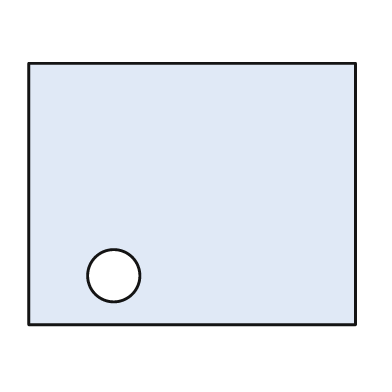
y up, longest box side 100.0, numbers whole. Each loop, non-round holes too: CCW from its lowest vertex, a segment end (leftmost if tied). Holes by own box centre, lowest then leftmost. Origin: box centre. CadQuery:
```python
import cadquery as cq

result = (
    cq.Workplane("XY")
    .moveTo(-50.0, -40.0)
    .lineTo(50.0, -40.0)
    .lineTo(50.0, 40.0)
    .lineTo(-50.0, 40.0)
    .close()
    .moveTo(-24.0, -25.0)
    .circle(8.0)
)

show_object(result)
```